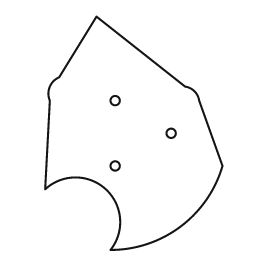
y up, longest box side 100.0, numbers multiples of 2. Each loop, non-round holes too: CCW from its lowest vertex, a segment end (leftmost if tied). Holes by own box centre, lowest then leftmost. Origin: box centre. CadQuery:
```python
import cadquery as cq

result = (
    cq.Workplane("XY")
    .moveTo(-10.0, -50.0)
    .threePointArc((20.0, -40.0), (38.0, -14.0))
    .lineTo(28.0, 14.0)
    .threePointArc((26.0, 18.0), (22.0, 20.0))
    .lineTo(-16.0, 50.0)
    .lineTo(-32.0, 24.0)
    .threePointArc((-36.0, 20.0), (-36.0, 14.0))
    .lineTo(-38.0, -24.0)
    .threePointArc((-12.0, -24.0), (-10.0, -50.0))
    .close()
    .moveTo(-8.0, -14.0)
    .circle(2.0)
    .moveTo(16.0, 0.0)
    .circle(2.0)
    .moveTo(-8.0, 14.0)
    .circle(2.0)
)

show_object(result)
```